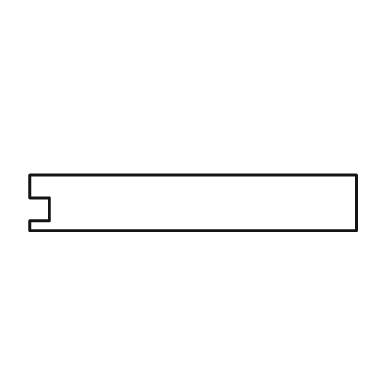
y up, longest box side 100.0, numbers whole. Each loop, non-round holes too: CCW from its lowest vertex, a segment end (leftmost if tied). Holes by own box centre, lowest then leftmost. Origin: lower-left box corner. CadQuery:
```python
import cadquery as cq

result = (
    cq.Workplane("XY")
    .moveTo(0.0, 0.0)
    .lineTo(100.0, 0.0)
    .lineTo(100.0, 17.0)
    .lineTo(0.0, 17.0)
    .lineTo(0.0, 10.0)
    .lineTo(6.0, 10.0)
    .lineTo(6.0, 3.0)
    .lineTo(0.0, 3.0)
    .close()
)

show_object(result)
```